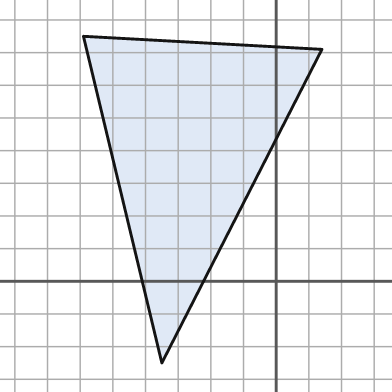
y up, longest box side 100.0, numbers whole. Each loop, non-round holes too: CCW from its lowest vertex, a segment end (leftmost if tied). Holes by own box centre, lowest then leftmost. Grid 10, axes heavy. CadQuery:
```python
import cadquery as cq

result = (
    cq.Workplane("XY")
    .moveTo(-35.0, -25.0)
    .lineTo(14.0, 71.0)
    .lineTo(-59.0, 75.0)
    .close()
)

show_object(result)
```